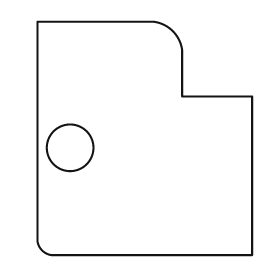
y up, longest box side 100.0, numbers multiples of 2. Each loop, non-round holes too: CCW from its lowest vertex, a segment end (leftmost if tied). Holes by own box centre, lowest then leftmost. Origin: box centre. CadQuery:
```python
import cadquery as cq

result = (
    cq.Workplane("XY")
    .moveTo(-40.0, -50.0)
    .lineTo(46.0, -50.0)
    .lineTo(46.0, 18.0)
    .lineTo(16.0, 18.0)
    .lineTo(16.0, 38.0)
    .threePointArc((12.0, 46.0), (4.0, 50.0))
    .lineTo(-46.0, 50.0)
    .lineTo(-46.0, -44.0)
    .threePointArc((-44.0, -48.0), (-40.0, -50.0))
    .close()
    .moveTo(-32.0, -4.0)
    .circle(10.0)
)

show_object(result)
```